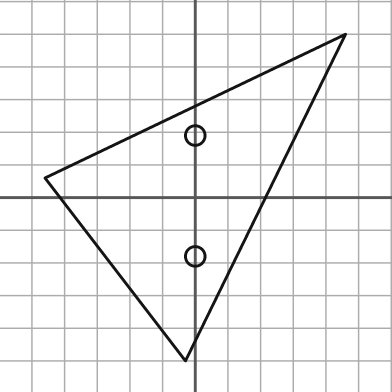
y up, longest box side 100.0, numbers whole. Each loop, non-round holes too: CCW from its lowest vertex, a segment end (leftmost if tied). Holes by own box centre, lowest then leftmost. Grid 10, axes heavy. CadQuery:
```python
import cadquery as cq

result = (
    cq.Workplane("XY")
    .moveTo(-3.0, -50.0)
    .lineTo(46.0, 50.0)
    .lineTo(-46.0, 6.0)
    .close()
    .moveTo(0.0, -18.0)
    .circle(3.0)
    .moveTo(0.0, 19.0)
    .circle(3.0)
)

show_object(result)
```